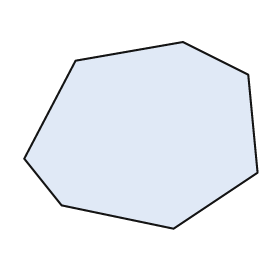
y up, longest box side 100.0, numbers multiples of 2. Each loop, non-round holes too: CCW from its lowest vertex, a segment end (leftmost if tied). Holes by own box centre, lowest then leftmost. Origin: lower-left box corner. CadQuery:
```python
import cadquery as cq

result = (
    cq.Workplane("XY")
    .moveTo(64.0, 0.0)
    .lineTo(100.0, 24.0)
    .lineTo(96.0, 66.0)
    .lineTo(68.0, 80.0)
    .lineTo(22.0, 72.0)
    .lineTo(0.0, 30.0)
    .lineTo(16.0, 10.0)
    .close()
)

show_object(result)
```